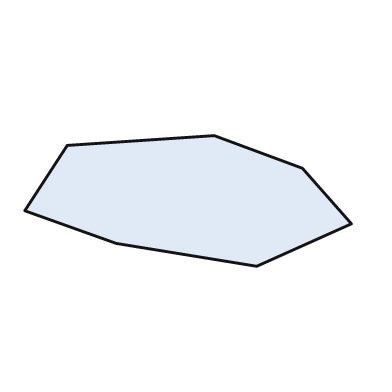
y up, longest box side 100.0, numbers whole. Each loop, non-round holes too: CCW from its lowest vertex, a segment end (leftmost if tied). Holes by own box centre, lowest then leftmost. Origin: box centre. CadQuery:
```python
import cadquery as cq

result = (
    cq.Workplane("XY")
    .moveTo(21.0, -20.0)
    .lineTo(50.0, -7.0)
    .lineTo(35.0, 10.0)
    .lineTo(8.0, 20.0)
    .lineTo(-37.0, 17.0)
    .lineTo(-50.0, -3.0)
    .lineTo(-22.0, -13.0)
    .close()
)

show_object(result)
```